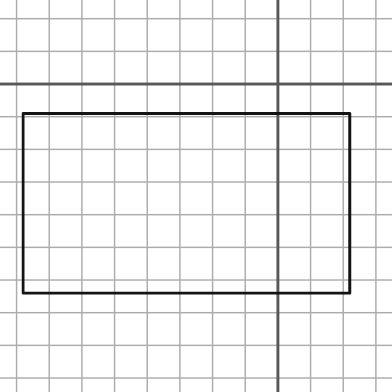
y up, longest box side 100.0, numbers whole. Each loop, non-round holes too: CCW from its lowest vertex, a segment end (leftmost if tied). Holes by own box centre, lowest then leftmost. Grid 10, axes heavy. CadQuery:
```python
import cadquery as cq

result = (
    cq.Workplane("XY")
    .moveTo(-78.0, -64.0)
    .lineTo(22.0, -64.0)
    .lineTo(22.0, -9.0)
    .lineTo(-78.0, -9.0)
    .close()
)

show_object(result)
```